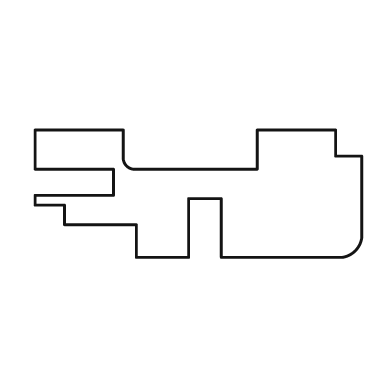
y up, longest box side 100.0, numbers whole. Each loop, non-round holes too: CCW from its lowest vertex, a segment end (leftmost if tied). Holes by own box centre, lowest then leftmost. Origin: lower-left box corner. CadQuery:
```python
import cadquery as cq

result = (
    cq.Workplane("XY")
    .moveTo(31.0, 0.0)
    .lineTo(47.0, 0.0)
    .lineTo(47.0, 18.0)
    .lineTo(57.0, 18.0)
    .lineTo(57.0, 0.0)
    .lineTo(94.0, 0.0)
    .threePointArc((98.0, 2.0), (100.0, 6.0))
    .lineTo(100.0, 31.0)
    .lineTo(92.0, 31.0)
    .lineTo(92.0, 39.0)
    .lineTo(68.0, 39.0)
    .lineTo(68.0, 27.0)
    .lineTo(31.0, 27.0)
    .threePointArc((28.0, 28.0), (27.0, 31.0))
    .lineTo(27.0, 39.0)
    .lineTo(0.0, 39.0)
    .lineTo(0.0, 27.0)
    .lineTo(24.0, 27.0)
    .lineTo(24.0, 19.0)
    .lineTo(0.0, 19.0)
    .lineTo(0.0, 16.0)
    .lineTo(9.0, 16.0)
    .lineTo(9.0, 10.0)
    .lineTo(31.0, 10.0)
    .close()
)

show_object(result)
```